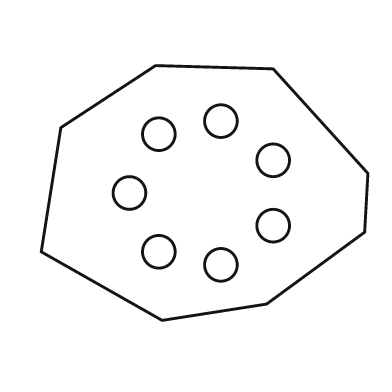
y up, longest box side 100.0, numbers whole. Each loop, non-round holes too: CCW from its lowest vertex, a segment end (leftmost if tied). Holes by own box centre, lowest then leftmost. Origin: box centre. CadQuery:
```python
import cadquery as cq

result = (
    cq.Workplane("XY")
    .moveTo(-13.0, -39.0)
    .lineTo(19.0, -34.0)
    .lineTo(49.0, -12.0)
    .lineTo(50.0, 6.0)
    .lineTo(21.0, 38.0)
    .lineTo(-15.0, 39.0)
    .lineTo(-44.0, 20.0)
    .lineTo(-50.0, -18.0)
    .close()
    .moveTo(5.0, -22.0)
    .circle(5.0)
    .moveTo(-14.0, -18.0)
    .circle(5.0)
    .moveTo(21.0, -10.0)
    .circle(5.0)
    .moveTo(-23.0, 0.0)
    .circle(5.0)
    .moveTo(21.0, 10.0)
    .circle(5.0)
    .moveTo(-14.0, 18.0)
    .circle(5.0)
    .moveTo(5.0, 22.0)
    .circle(5.0)
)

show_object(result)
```